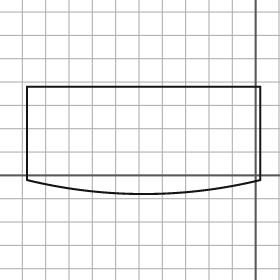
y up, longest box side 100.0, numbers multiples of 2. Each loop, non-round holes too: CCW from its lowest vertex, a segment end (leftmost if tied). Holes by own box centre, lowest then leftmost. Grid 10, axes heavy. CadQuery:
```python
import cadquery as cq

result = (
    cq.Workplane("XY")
    .moveTo(-98.0, -2.0)
    .threePointArc((-48.0, -8.0), (2.0, -2.0))
    .lineTo(2.0, 38.0)
    .lineTo(-98.0, 38.0)
    .close()
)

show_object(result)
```